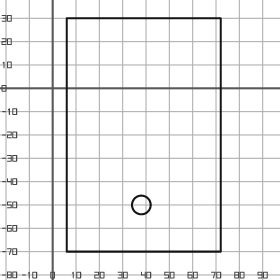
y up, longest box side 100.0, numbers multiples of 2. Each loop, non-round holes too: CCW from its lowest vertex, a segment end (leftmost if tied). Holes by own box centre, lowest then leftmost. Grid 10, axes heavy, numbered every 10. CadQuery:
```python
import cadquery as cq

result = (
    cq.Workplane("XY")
    .moveTo(6.0, -70.0)
    .lineTo(72.0, -70.0)
    .lineTo(72.0, 30.0)
    .lineTo(6.0, 30.0)
    .close()
    .moveTo(38.0, -50.0)
    .circle(4.0)
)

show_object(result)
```